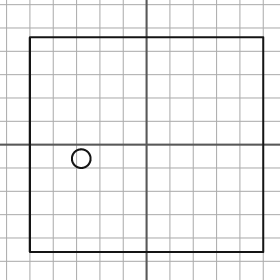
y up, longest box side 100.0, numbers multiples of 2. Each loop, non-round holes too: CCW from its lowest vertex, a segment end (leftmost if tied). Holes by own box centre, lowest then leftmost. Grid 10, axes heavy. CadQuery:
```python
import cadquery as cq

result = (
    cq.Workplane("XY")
    .moveTo(-50.0, -46.0)
    .lineTo(50.0, -46.0)
    .lineTo(50.0, 46.0)
    .lineTo(-50.0, 46.0)
    .close()
    .moveTo(-28.0, -6.0)
    .circle(4.0)
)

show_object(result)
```